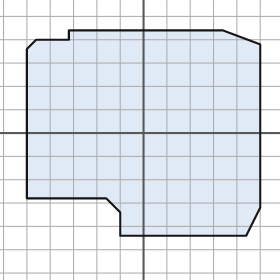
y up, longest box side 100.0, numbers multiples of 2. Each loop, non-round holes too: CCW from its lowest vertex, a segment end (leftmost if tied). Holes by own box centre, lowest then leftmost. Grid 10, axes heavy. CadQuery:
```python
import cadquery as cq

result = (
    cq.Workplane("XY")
    .moveTo(-10.0, -44.0)
    .lineTo(44.0, -44.0)
    .lineTo(50.0, -32.0)
    .lineTo(50.0, 38.0)
    .lineTo(34.0, 44.0)
    .lineTo(-32.0, 44.0)
    .lineTo(-32.0, 40.0)
    .lineTo(-46.0, 40.0)
    .lineTo(-50.0, 36.0)
    .lineTo(-50.0, -28.0)
    .lineTo(-16.0, -28.0)
    .lineTo(-10.0, -34.0)
    .close()
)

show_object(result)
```